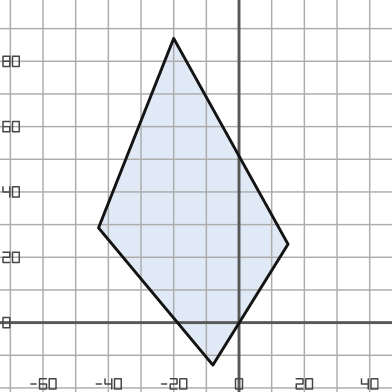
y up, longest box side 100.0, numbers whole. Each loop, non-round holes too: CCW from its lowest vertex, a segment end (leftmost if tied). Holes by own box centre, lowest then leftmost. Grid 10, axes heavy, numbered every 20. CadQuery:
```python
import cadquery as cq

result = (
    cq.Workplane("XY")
    .moveTo(-8.0, -13.0)
    .lineTo(15.0, 24.0)
    .lineTo(-20.0, 87.0)
    .lineTo(-43.0, 29.0)
    .close()
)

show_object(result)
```